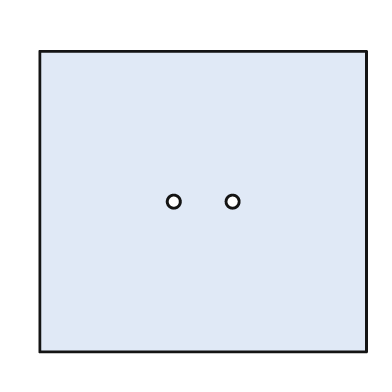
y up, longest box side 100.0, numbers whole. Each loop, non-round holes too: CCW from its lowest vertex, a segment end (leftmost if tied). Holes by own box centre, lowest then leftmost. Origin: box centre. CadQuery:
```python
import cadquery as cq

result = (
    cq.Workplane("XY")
    .moveTo(-50.0, -46.0)
    .lineTo(50.0, -46.0)
    .lineTo(50.0, 46.0)
    .lineTo(-50.0, 46.0)
    .close()
    .moveTo(-9.0, 0.0)
    .circle(2.0)
    .moveTo(9.0, 0.0)
    .circle(2.0)
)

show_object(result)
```